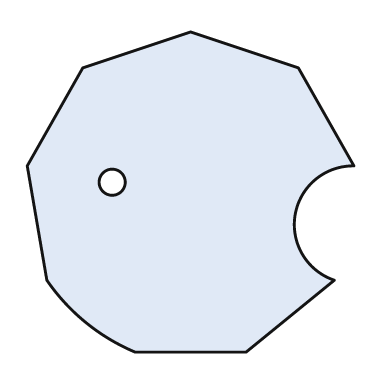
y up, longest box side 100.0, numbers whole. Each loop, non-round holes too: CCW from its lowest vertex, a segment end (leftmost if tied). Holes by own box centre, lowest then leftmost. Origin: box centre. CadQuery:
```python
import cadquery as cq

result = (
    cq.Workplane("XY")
    .moveTo(-17.0, -49.0)
    .lineTo(17.0, -49.0)
    .lineTo(44.0, -27.0)
    .threePointArc((32.0, -7.0), (50.0, 8.0))
    .lineTo(33.0, 38.0)
    .lineTo(0.0, 49.0)
    .lineTo(-33.0, 38.0)
    .lineTo(-50.0, 8.0)
    .lineTo(-44.0, -27.0)
    .threePointArc((-32.0, -40.0), (-17.0, -49.0))
    .close()
    .moveTo(-24.0, 3.0)
    .circle(4.0)
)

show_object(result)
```